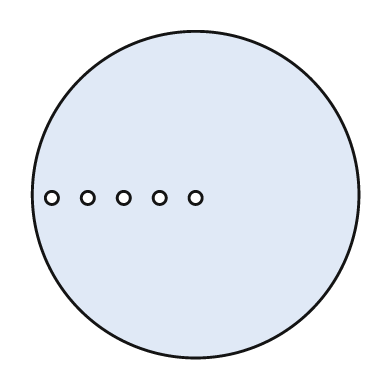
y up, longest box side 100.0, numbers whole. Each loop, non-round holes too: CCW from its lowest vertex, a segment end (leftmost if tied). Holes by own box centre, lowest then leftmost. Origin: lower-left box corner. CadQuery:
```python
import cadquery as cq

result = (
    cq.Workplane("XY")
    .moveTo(50.0, 50.0)
    .circle(50.0)
    .moveTo(6.0, 49.0)
    .circle(2.0)
    .moveTo(17.0, 49.0)
    .circle(2.0)
    .moveTo(28.0, 49.0)
    .circle(2.0)
    .moveTo(39.0, 49.0)
    .circle(2.0)
    .moveTo(50.0, 49.0)
    .circle(2.0)
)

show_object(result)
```